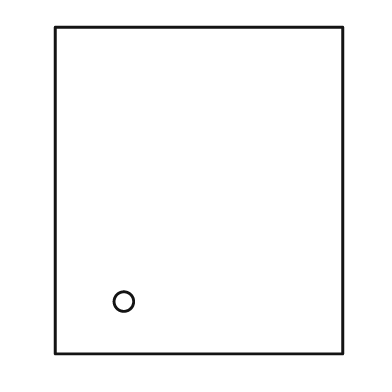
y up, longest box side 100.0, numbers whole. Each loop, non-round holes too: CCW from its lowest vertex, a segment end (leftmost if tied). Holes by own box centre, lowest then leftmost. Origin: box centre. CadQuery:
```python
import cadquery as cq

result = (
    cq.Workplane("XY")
    .moveTo(-44.0, -50.0)
    .lineTo(44.0, -50.0)
    .lineTo(44.0, 50.0)
    .lineTo(-44.0, 50.0)
    .close()
    .moveTo(-23.0, -34.0)
    .circle(3.0)
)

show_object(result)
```